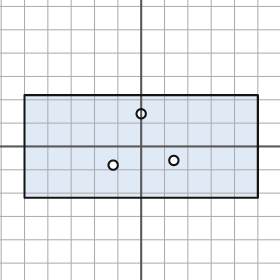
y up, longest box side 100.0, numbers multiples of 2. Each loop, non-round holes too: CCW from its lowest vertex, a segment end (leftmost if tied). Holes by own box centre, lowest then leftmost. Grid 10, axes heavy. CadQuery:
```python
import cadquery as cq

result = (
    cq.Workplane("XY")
    .moveTo(-50.0, -22.0)
    .lineTo(50.0, -22.0)
    .lineTo(50.0, 22.0)
    .lineTo(-50.0, 22.0)
    .close()
    .moveTo(-12.0, -8.0)
    .circle(2.0)
    .moveTo(14.0, -6.0)
    .circle(2.0)
    .moveTo(0.0, 14.0)
    .circle(2.0)
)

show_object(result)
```